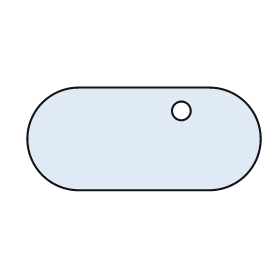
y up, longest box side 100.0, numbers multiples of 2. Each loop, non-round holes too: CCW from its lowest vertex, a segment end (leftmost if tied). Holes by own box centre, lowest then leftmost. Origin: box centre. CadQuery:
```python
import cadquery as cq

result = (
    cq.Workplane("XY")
    .moveTo(-28.0, -22.0)
    .lineTo(28.0, -22.0)
    .threePointArc((50.0, 0.0), (28.0, 22.0))
    .lineTo(-28.0, 22.0)
    .threePointArc((-50.0, 0.0), (-28.0, -22.0))
    .close()
    .moveTo(16.0, 12.0)
    .circle(4.0)
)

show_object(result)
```